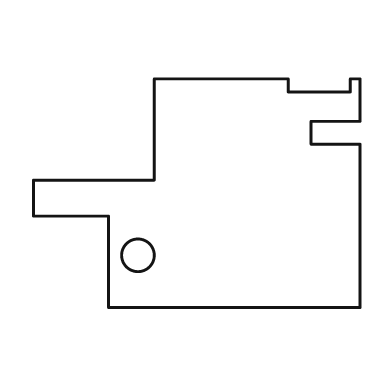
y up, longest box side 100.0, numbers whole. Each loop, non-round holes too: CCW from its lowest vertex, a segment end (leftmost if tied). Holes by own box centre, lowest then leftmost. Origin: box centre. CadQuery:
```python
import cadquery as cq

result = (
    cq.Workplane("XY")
    .moveTo(-27.0, -35.0)
    .lineTo(50.0, -35.0)
    .lineTo(50.0, 15.0)
    .lineTo(35.0, 15.0)
    .lineTo(35.0, 22.0)
    .lineTo(50.0, 22.0)
    .lineTo(50.0, 35.0)
    .lineTo(47.0, 35.0)
    .lineTo(47.0, 31.0)
    .lineTo(28.0, 31.0)
    .lineTo(28.0, 35.0)
    .lineTo(-13.0, 35.0)
    .lineTo(-13.0, 4.0)
    .lineTo(-50.0, 4.0)
    .lineTo(-50.0, -7.0)
    .lineTo(-27.0, -7.0)
    .close()
    .moveTo(-18.0, -19.0)
    .circle(5.0)
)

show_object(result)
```